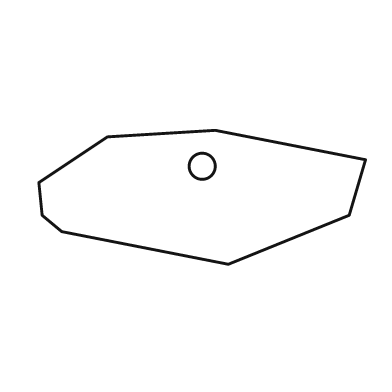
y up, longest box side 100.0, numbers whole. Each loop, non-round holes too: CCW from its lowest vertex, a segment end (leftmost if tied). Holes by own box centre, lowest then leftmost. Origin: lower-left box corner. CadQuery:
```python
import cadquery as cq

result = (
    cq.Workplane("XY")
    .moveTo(58.0, 0.0)
    .lineTo(95.0, 15.0)
    .lineTo(100.0, 32.0)
    .lineTo(54.0, 41.0)
    .lineTo(21.0, 39.0)
    .lineTo(0.0, 25.0)
    .lineTo(1.0, 15.0)
    .lineTo(7.0, 10.0)
    .close()
    .moveTo(50.0, 30.0)
    .circle(4.0)
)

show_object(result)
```